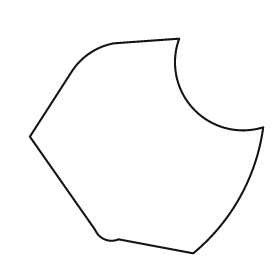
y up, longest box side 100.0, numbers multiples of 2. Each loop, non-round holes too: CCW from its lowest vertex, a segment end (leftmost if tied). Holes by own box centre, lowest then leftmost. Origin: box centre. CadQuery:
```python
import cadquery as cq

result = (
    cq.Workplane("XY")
    .moveTo(20.0, -46.0)
    .threePointArc((40.0, -22.0), (50.0, 8.0))
    .threePointArc((20.0, 16.0), (14.0, 46.0))
    .lineTo(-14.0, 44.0)
    .threePointArc((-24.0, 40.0), (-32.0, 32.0))
    .lineTo(-50.0, 4.0)
    .lineTo(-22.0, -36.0)
    .threePointArc((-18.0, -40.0), (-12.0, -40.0))
    .close()
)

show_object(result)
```